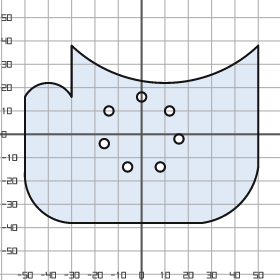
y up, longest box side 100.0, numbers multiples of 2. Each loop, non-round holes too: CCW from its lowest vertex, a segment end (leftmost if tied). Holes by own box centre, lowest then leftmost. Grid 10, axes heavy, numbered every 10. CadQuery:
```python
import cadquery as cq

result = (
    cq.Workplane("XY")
    .moveTo(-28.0, -38.0)
    .lineTo(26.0, -38.0)
    .threePointArc((42.0, -30.0), (50.0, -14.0))
    .lineTo(50.0, 38.0)
    .threePointArc((10.0, 22.0), (-30.0, 38.0))
    .lineTo(-30.0, 16.0)
    .threePointArc((-40.0, 22.0), (-50.0, 16.0))
    .lineTo(-50.0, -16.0)
    .threePointArc((-44.0, -32.0), (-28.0, -38.0))
    .close()
    .moveTo(-6.0, -14.0)
    .circle(2.0)
    .moveTo(8.0, -14.0)
    .circle(2.0)
    .moveTo(-16.0, -4.0)
    .circle(2.0)
    .moveTo(16.0, -2.0)
    .circle(2.0)
    .moveTo(-14.0, 10.0)
    .circle(2.0)
    .moveTo(12.0, 10.0)
    .circle(2.0)
    .moveTo(0.0, 16.0)
    .circle(2.0)
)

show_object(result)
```